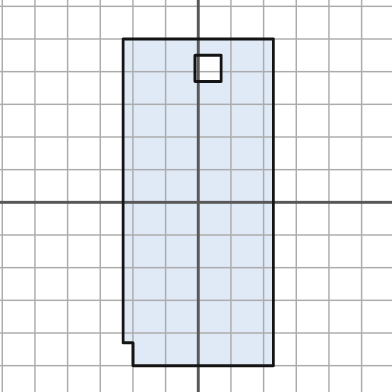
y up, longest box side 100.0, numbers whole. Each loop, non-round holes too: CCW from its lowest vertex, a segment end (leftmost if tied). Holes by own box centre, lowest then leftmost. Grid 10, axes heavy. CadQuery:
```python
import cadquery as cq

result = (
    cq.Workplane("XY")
    .moveTo(-20.0, -50.0)
    .lineTo(23.0, -50.0)
    .lineTo(23.0, 50.0)
    .lineTo(-23.0, 50.0)
    .lineTo(-23.0, -43.0)
    .lineTo(-20.0, -43.0)
    .close()
    .moveTo(-1.0, 37.0)
    .lineTo(7.0, 37.0)
    .lineTo(7.0, 45.0)
    .lineTo(-1.0, 45.0)
    .close()
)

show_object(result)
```